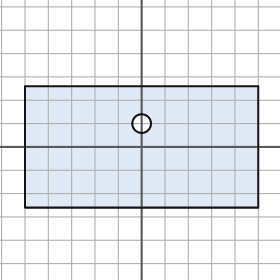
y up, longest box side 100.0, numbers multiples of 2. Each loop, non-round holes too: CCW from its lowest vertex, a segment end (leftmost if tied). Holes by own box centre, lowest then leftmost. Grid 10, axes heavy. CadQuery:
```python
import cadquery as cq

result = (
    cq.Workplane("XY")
    .moveTo(-50.0, -26.0)
    .lineTo(50.0, -26.0)
    .lineTo(50.0, 26.0)
    .lineTo(-50.0, 26.0)
    .close()
    .moveTo(0.0, 10.0)
    .circle(4.0)
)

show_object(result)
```